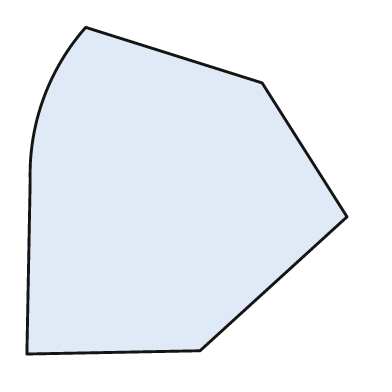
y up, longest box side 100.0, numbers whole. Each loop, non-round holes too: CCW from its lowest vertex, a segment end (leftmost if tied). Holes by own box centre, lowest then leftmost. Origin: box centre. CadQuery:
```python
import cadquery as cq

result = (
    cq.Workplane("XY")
    .moveTo(-49.0, -50.0)
    .lineTo(4.0, -49.0)
    .lineTo(49.0, -8.0)
    .lineTo(23.0, 33.0)
    .lineTo(-31.0, 50.0)
    .threePointArc((-44.0, 28.0), (-48.0, 3.0))
    .close()
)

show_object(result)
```